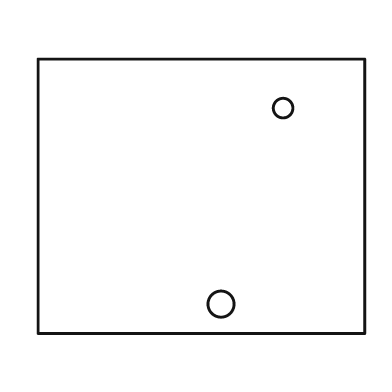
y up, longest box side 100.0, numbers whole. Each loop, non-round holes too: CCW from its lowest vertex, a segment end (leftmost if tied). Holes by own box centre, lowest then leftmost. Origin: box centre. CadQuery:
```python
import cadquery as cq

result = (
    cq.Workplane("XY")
    .moveTo(-50.0, -42.0)
    .lineTo(50.0, -42.0)
    .lineTo(50.0, 42.0)
    .lineTo(-50.0, 42.0)
    .close()
    .moveTo(6.0, -33.0)
    .circle(4.0)
    .moveTo(25.0, 27.0)
    .circle(3.0)
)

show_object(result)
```